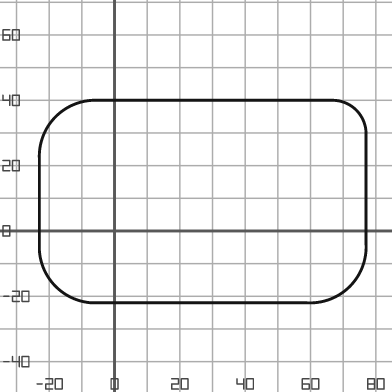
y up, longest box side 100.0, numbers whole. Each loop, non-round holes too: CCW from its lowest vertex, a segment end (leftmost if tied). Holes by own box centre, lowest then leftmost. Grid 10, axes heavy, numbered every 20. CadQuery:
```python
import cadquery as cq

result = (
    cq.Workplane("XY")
    .moveTo(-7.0, -22.0)
    .lineTo(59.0, -22.0)
    .threePointArc((72.0, -17.0), (77.0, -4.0))
    .lineTo(77.0, 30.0)
    .threePointArc((74.0, 37.0), (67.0, 40.0))
    .lineTo(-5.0, 40.0)
    .threePointArc((-18.0, 35.0), (-23.0, 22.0))
    .lineTo(-23.0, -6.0)
    .threePointArc((-18.0, -17.0), (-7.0, -22.0))
    .close()
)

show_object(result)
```